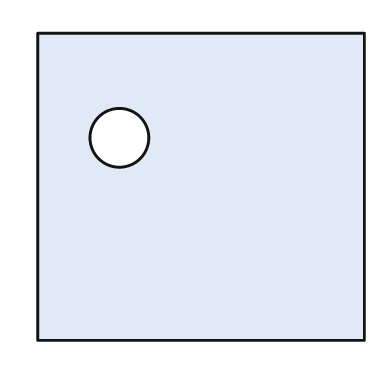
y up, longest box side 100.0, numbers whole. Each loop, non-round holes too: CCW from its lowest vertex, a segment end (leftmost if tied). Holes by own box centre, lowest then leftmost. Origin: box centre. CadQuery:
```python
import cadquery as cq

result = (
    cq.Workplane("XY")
    .moveTo(-50.0, -47.0)
    .lineTo(50.0, -47.0)
    .lineTo(50.0, 47.0)
    .lineTo(-50.0, 47.0)
    .close()
    .moveTo(-25.0, 15.0)
    .circle(9.0)
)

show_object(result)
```